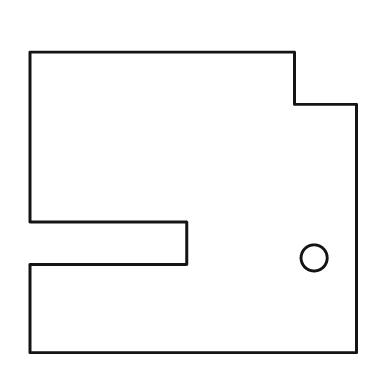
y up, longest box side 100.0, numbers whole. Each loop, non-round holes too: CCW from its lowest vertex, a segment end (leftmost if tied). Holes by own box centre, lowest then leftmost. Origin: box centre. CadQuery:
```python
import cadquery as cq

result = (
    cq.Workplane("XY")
    .moveTo(-50.0, -46.0)
    .lineTo(50.0, -46.0)
    .lineTo(50.0, 30.0)
    .lineTo(31.0, 30.0)
    .lineTo(31.0, 46.0)
    .lineTo(-50.0, 46.0)
    .lineTo(-50.0, -6.0)
    .lineTo(-2.0, -6.0)
    .lineTo(-2.0, -19.0)
    .lineTo(-50.0, -19.0)
    .close()
    .moveTo(37.0, -17.0)
    .circle(4.0)
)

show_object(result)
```